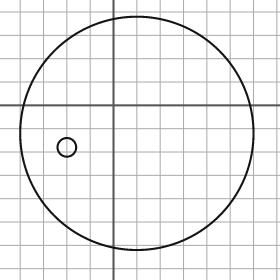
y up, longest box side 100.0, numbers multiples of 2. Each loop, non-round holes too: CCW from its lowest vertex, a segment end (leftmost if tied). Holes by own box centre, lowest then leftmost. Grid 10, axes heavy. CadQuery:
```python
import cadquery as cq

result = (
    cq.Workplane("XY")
    .moveTo(10.0, -12.0)
    .circle(50.0)
    .moveTo(-20.0, -18.0)
    .circle(4.0)
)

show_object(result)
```